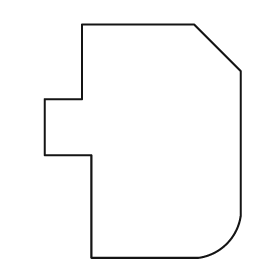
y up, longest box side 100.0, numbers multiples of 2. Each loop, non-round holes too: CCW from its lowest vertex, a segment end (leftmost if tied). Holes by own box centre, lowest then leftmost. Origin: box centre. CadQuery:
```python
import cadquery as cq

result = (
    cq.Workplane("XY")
    .moveTo(-22.0, -50.0)
    .lineTo(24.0, -50.0)
    .threePointArc((36.0, -44.0), (42.0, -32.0))
    .lineTo(42.0, 30.0)
    .lineTo(22.0, 50.0)
    .lineTo(-26.0, 50.0)
    .lineTo(-26.0, 18.0)
    .lineTo(-42.0, 18.0)
    .lineTo(-42.0, -6.0)
    .lineTo(-22.0, -6.0)
    .close()
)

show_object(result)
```